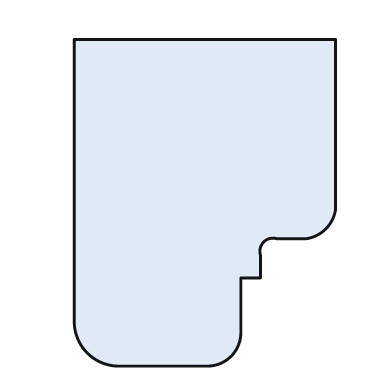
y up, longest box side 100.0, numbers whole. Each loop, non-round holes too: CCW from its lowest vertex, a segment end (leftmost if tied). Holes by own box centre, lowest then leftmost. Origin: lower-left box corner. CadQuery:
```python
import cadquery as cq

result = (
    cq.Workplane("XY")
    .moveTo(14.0, 0.0)
    .lineTo(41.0, 0.0)
    .threePointArc((48.0, 3.0), (51.0, 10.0))
    .lineTo(51.0, 27.0)
    .lineTo(57.0, 27.0)
    .lineTo(57.0, 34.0)
    .threePointArc((58.0, 38.0), (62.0, 39.0))
    .lineTo(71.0, 39.0)
    .threePointArc((77.0, 42.0), (80.0, 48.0))
    .lineTo(80.0, 100.0)
    .lineTo(0.0, 100.0)
    .lineTo(0.0, 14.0)
    .threePointArc((4.0, 4.0), (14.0, 0.0))
    .close()
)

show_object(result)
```